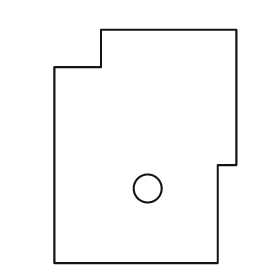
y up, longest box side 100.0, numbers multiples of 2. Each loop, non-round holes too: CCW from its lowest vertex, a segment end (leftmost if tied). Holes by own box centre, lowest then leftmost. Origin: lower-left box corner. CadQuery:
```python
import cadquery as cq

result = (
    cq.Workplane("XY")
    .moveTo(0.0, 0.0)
    .lineTo(70.0, 0.0)
    .lineTo(70.0, 42.0)
    .lineTo(78.0, 42.0)
    .lineTo(78.0, 100.0)
    .lineTo(20.0, 100.0)
    .lineTo(20.0, 84.0)
    .lineTo(0.0, 84.0)
    .close()
    .moveTo(40.0, 32.0)
    .circle(6.0)
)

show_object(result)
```